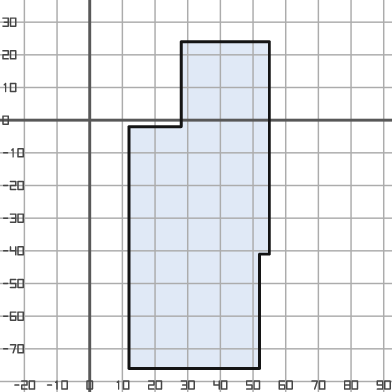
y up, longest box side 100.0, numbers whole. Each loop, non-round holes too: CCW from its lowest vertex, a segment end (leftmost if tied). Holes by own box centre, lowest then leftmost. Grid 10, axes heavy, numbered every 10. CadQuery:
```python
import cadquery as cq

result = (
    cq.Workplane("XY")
    .moveTo(12.0, -76.0)
    .lineTo(52.0, -76.0)
    .lineTo(52.0, -41.0)
    .lineTo(55.0, -41.0)
    .lineTo(55.0, 24.0)
    .lineTo(28.0, 24.0)
    .lineTo(28.0, -2.0)
    .lineTo(12.0, -2.0)
    .close()
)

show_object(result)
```